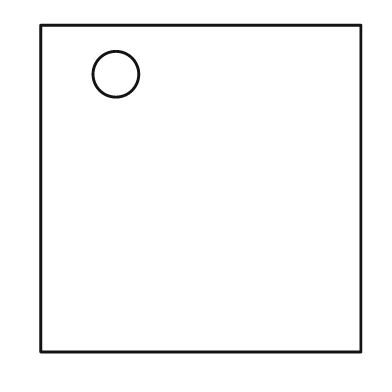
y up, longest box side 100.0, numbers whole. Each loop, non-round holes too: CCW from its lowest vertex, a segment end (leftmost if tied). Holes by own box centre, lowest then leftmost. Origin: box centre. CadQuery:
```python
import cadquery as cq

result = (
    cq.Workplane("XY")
    .moveTo(-49.0, -50.0)
    .lineTo(49.0, -50.0)
    .lineTo(49.0, 50.0)
    .lineTo(-49.0, 50.0)
    .close()
    .moveTo(-26.0, 35.0)
    .circle(7.0)
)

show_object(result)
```